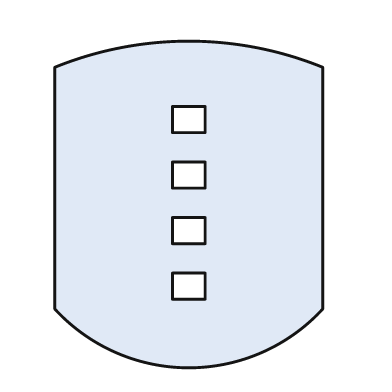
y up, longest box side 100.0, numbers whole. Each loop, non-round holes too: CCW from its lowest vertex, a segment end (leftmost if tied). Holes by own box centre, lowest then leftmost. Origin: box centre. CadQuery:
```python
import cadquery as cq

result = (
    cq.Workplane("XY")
    .moveTo(-41.0, -32.0)
    .threePointArc((0.0, -50.0), (41.0, -32.0))
    .lineTo(41.0, 42.0)
    .threePointArc((0.0, 50.0), (-41.0, 42.0))
    .close()
    .moveTo(-5.0, -29.0)
    .lineTo(5.0, -29.0)
    .lineTo(5.0, -21.0)
    .lineTo(-5.0, -21.0)
    .close()
    .moveTo(-5.0, -12.0)
    .lineTo(5.0, -12.0)
    .lineTo(5.0, -4.0)
    .lineTo(-5.0, -4.0)
    .close()
    .moveTo(-5.0, 5.0)
    .lineTo(5.0, 5.0)
    .lineTo(5.0, 13.0)
    .lineTo(-5.0, 13.0)
    .close()
    .moveTo(-5.0, 22.0)
    .lineTo(5.0, 22.0)
    .lineTo(5.0, 30.0)
    .lineTo(-5.0, 30.0)
    .close()
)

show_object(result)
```